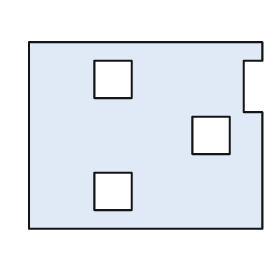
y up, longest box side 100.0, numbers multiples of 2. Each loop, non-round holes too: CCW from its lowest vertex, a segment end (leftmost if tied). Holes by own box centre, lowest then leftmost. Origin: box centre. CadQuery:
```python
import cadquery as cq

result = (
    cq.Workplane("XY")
    .moveTo(-50.0, -40.0)
    .lineTo(50.0, -40.0)
    .lineTo(50.0, 10.0)
    .lineTo(42.0, 10.0)
    .lineTo(42.0, 32.0)
    .lineTo(50.0, 32.0)
    .lineTo(50.0, 40.0)
    .lineTo(-50.0, 40.0)
    .close()
    .moveTo(-22.0, -32.0)
    .lineTo(-6.0, -32.0)
    .lineTo(-6.0, -16.0)
    .lineTo(-22.0, -16.0)
    .close()
    .moveTo(20.0, -8.0)
    .lineTo(36.0, -8.0)
    .lineTo(36.0, 8.0)
    .lineTo(20.0, 8.0)
    .close()
    .moveTo(-22.0, 16.0)
    .lineTo(-6.0, 16.0)
    .lineTo(-6.0, 32.0)
    .lineTo(-22.0, 32.0)
    .close()
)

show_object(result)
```